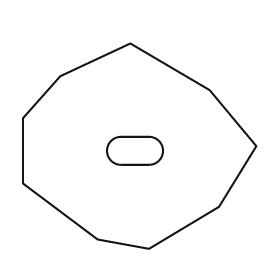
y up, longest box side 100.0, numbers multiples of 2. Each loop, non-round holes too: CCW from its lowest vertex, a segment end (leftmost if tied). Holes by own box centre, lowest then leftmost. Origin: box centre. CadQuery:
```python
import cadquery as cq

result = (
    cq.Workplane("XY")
    .moveTo(4.0, -44.0)
    .lineTo(34.0, -26.0)
    .lineTo(50.0, 0.0)
    .lineTo(30.0, 24.0)
    .lineTo(-4.0, 44.0)
    .lineTo(-34.0, 30.0)
    .lineTo(-50.0, 12.0)
    .lineTo(-50.0, -16.0)
    .lineTo(-18.0, -40.0)
    .close()
    .moveTo(-8.0, -8.0)
    .lineTo(4.0, -8.0)
    .threePointArc((10.0, -2.0), (4.0, 4.0))
    .lineTo(-8.0, 4.0)
    .threePointArc((-14.0, -2.0), (-8.0, -8.0))
    .close()
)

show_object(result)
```